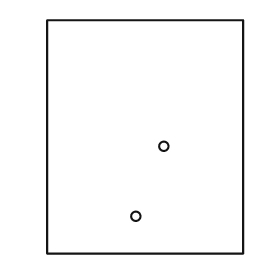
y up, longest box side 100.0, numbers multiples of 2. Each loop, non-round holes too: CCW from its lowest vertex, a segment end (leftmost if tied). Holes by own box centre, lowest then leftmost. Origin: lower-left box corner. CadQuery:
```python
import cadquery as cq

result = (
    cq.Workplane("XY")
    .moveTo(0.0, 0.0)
    .lineTo(84.0, 0.0)
    .lineTo(84.0, 100.0)
    .lineTo(0.0, 100.0)
    .close()
    .moveTo(38.0, 16.0)
    .circle(2.0)
    .moveTo(50.0, 46.0)
    .circle(2.0)
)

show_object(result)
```